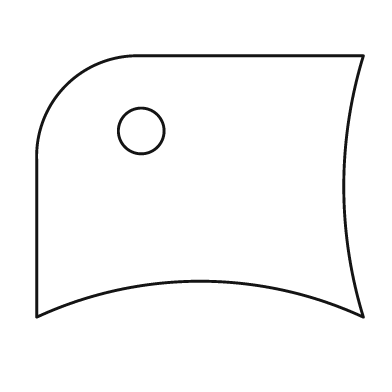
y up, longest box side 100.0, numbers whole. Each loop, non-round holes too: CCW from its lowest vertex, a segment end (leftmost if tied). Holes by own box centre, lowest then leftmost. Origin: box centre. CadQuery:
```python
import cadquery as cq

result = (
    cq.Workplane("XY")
    .moveTo(-50.0, -40.0)
    .threePointArc((0.0, -29.0), (50.0, -40.0))
    .threePointArc((44.0, 0.0), (50.0, 40.0))
    .lineTo(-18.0, 40.0)
    .threePointArc((-41.0, 31.0), (-50.0, 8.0))
    .close()
    .moveTo(-18.0, 17.0)
    .circle(7.0)
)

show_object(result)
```